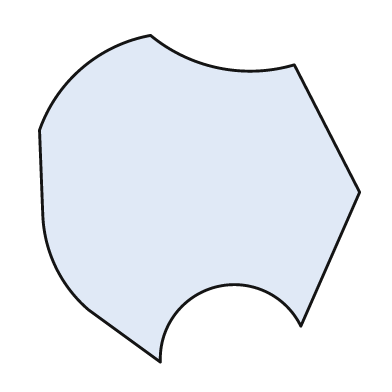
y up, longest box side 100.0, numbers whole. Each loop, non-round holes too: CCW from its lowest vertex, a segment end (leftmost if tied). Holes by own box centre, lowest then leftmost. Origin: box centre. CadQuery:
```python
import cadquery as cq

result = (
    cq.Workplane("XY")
    .moveTo(-12.0, -50.0)
    .threePointArc((5.0, -27.0), (31.0, -39.0))
    .lineTo(49.0, 2.0)
    .lineTo(29.0, 41.0)
    .threePointArc((6.0, 40.0), (-15.0, 50.0))
    .threePointArc((-36.0, 40.0), (-49.0, 21.0))
    .lineTo(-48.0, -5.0)
    .threePointArc((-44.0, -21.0), (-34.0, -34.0))
    .close()
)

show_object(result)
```